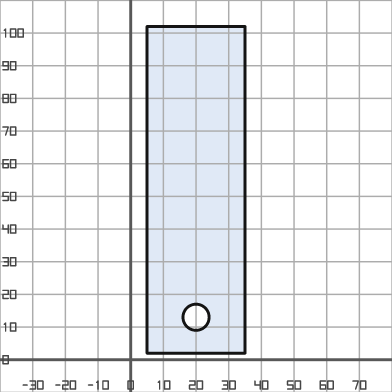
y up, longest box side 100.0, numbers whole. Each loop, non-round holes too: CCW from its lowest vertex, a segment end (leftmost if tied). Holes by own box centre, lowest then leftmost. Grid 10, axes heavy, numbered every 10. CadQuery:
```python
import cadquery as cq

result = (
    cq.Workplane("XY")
    .moveTo(5.0, 2.0)
    .lineTo(35.0, 2.0)
    .lineTo(35.0, 102.0)
    .lineTo(5.0, 102.0)
    .close()
    .moveTo(20.0, 13.0)
    .circle(4.0)
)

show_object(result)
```